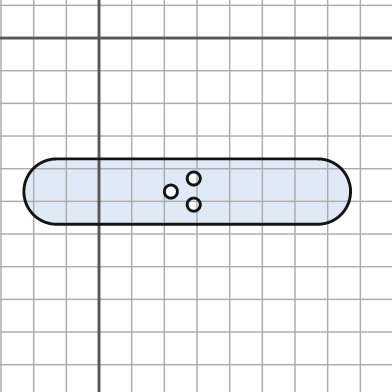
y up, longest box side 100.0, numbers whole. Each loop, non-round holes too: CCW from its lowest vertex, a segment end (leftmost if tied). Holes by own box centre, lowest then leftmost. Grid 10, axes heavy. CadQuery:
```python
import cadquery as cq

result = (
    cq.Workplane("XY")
    .moveTo(-13.0, -57.0)
    .lineTo(67.0, -57.0)
    .threePointArc((77.0, -47.0), (67.0, -37.0))
    .lineTo(-13.0, -37.0)
    .threePointArc((-23.0, -47.0), (-13.0, -57.0))
    .close()
    .moveTo(29.0, -51.0)
    .circle(2.0)
    .moveTo(22.0, -47.0)
    .circle(2.0)
    .moveTo(29.0, -43.0)
    .circle(2.0)
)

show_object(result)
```